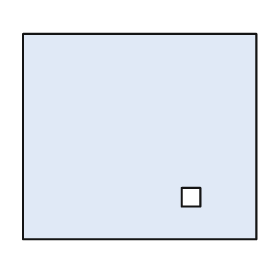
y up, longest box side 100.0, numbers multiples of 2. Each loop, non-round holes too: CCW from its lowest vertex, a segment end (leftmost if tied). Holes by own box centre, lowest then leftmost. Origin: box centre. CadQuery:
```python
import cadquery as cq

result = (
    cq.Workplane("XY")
    .moveTo(-50.0, -44.0)
    .lineTo(50.0, -44.0)
    .lineTo(50.0, 44.0)
    .lineTo(-50.0, 44.0)
    .close()
    .moveTo(18.0, -30.0)
    .lineTo(26.0, -30.0)
    .lineTo(26.0, -22.0)
    .lineTo(18.0, -22.0)
    .close()
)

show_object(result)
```